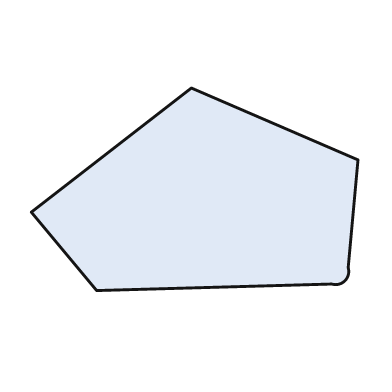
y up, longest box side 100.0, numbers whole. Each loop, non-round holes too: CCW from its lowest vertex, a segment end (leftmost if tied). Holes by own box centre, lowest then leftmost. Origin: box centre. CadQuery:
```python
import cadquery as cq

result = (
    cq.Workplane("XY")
    .moveTo(-30.0, -31.0)
    .lineTo(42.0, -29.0)
    .threePointArc((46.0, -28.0), (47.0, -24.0))
    .lineTo(50.0, 9.0)
    .lineTo(-1.0, 31.0)
    .lineTo(-50.0, -7.0)
    .close()
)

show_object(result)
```